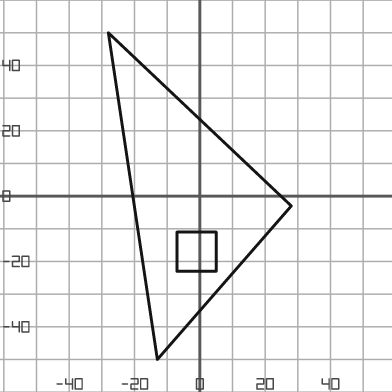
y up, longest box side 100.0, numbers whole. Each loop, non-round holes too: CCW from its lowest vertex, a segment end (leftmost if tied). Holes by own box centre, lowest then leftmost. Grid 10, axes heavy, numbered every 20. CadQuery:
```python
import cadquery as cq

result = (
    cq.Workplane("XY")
    .moveTo(-13.0, -50.0)
    .lineTo(28.0, -3.0)
    .lineTo(-28.0, 50.0)
    .close()
    .moveTo(-7.0, -23.0)
    .lineTo(5.0, -23.0)
    .lineTo(5.0, -11.0)
    .lineTo(-7.0, -11.0)
    .close()
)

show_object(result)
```